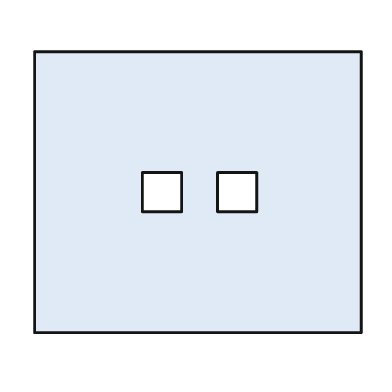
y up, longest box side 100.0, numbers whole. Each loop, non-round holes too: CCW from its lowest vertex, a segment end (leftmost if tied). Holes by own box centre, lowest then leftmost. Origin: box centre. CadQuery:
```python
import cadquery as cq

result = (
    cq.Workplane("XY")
    .moveTo(-50.0, -43.0)
    .lineTo(50.0, -43.0)
    .lineTo(50.0, 43.0)
    .lineTo(-50.0, 43.0)
    .close()
    .moveTo(-17.0, -6.0)
    .lineTo(-5.0, -6.0)
    .lineTo(-5.0, 6.0)
    .lineTo(-17.0, 6.0)
    .close()
    .moveTo(6.0, -6.0)
    .lineTo(18.0, -6.0)
    .lineTo(18.0, 6.0)
    .lineTo(6.0, 6.0)
    .close()
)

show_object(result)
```